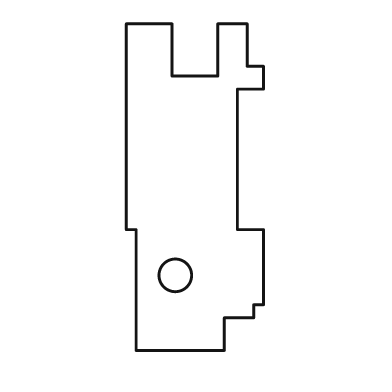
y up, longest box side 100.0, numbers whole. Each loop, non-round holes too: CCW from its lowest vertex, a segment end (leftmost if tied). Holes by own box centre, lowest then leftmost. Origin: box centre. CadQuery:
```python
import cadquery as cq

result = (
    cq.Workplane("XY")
    .moveTo(-18.0, -50.0)
    .lineTo(9.0, -50.0)
    .lineTo(9.0, -40.0)
    .lineTo(18.0, -40.0)
    .lineTo(18.0, -36.0)
    .lineTo(21.0, -36.0)
    .lineTo(21.0, -13.0)
    .lineTo(13.0, -13.0)
    .lineTo(13.0, 30.0)
    .lineTo(21.0, 30.0)
    .lineTo(21.0, 37.0)
    .lineTo(16.0, 37.0)
    .lineTo(16.0, 50.0)
    .lineTo(7.0, 50.0)
    .lineTo(7.0, 34.0)
    .lineTo(-7.0, 34.0)
    .lineTo(-7.0, 50.0)
    .lineTo(-21.0, 50.0)
    .lineTo(-21.0, -13.0)
    .lineTo(-18.0, -13.0)
    .close()
    .moveTo(-6.0, -27.0)
    .circle(5.0)
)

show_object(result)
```